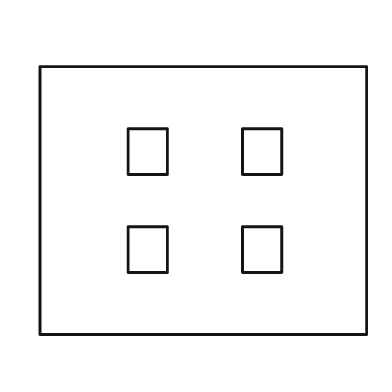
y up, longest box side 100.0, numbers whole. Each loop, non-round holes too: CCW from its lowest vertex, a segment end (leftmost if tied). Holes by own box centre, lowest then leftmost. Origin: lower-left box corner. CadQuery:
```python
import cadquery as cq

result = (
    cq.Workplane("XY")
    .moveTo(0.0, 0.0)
    .lineTo(100.0, 0.0)
    .lineTo(100.0, 82.0)
    .lineTo(0.0, 82.0)
    .close()
    .moveTo(27.0, 19.0)
    .lineTo(39.0, 19.0)
    .lineTo(39.0, 33.0)
    .lineTo(27.0, 33.0)
    .close()
    .moveTo(62.0, 19.0)
    .lineTo(74.0, 19.0)
    .lineTo(74.0, 33.0)
    .lineTo(62.0, 33.0)
    .close()
    .moveTo(27.0, 49.0)
    .lineTo(39.0, 49.0)
    .lineTo(39.0, 63.0)
    .lineTo(27.0, 63.0)
    .close()
    .moveTo(62.0, 49.0)
    .lineTo(74.0, 49.0)
    .lineTo(74.0, 63.0)
    .lineTo(62.0, 63.0)
    .close()
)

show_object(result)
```